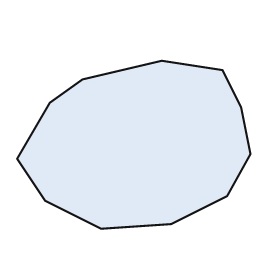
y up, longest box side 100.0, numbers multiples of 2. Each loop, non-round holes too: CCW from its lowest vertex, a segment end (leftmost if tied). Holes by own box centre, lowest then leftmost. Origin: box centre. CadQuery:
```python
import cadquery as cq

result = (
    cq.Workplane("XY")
    .moveTo(-14.0, -36.0)
    .lineTo(16.0, -34.0)
    .lineTo(40.0, -22.0)
    .lineTo(50.0, -4.0)
    .lineTo(46.0, 16.0)
    .lineTo(38.0, 32.0)
    .lineTo(12.0, 36.0)
    .lineTo(-22.0, 28.0)
    .lineTo(-36.0, 18.0)
    .lineTo(-50.0, -6.0)
    .lineTo(-38.0, -24.0)
    .close()
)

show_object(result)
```